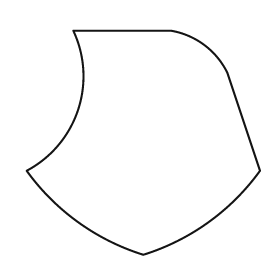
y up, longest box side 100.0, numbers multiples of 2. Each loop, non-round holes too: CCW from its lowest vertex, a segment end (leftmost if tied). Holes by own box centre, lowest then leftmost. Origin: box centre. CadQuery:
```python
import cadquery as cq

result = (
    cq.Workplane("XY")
    .moveTo(0.0, -48.0)
    .threePointArc((28.0, -34.0), (50.0, -12.0))
    .lineTo(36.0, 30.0)
    .threePointArc((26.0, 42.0), (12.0, 48.0))
    .lineTo(-30.0, 48.0)
    .threePointArc((-28.0, 14.0), (-50.0, -12.0))
    .threePointArc((-28.0, -34.0), (0.0, -48.0))
    .close()
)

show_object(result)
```